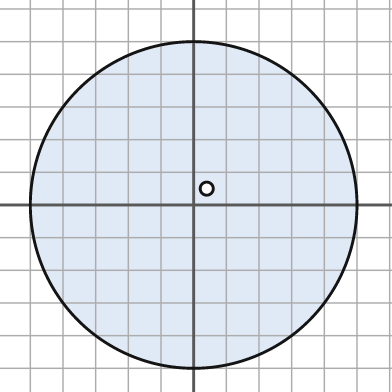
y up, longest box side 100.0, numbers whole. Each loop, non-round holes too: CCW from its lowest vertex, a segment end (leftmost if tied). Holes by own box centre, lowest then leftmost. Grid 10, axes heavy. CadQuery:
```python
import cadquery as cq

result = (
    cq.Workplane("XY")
    .moveTo(0.0, 0.0)
    .circle(50.0)
    .moveTo(4.0, 5.0)
    .circle(2.0)
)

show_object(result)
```